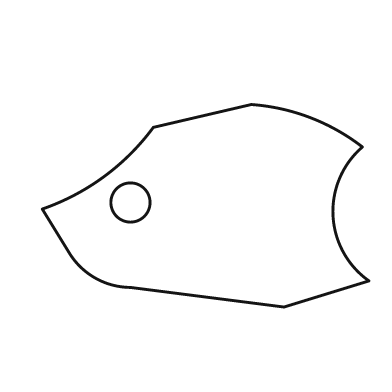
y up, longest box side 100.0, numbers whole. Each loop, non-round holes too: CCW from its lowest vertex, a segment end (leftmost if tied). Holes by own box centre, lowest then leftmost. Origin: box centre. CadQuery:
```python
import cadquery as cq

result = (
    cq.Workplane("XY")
    .moveTo(24.0, -31.0)
    .lineTo(50.0, -23.0)
    .threePointArc((39.0, -3.0), (48.0, 18.0))
    .threePointArc((32.0, 27.0), (14.0, 31.0))
    .lineTo(-16.0, 24.0)
    .threePointArc((-31.0, 9.0), (-50.0, -1.0))
    .lineTo(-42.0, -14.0)
    .threePointArc((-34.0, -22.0), (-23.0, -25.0))
    .close()
    .moveTo(-23.0, 1.0)
    .circle(6.0)
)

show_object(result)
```